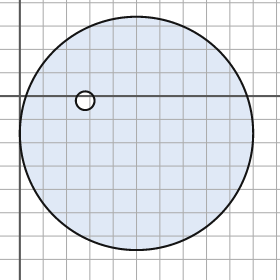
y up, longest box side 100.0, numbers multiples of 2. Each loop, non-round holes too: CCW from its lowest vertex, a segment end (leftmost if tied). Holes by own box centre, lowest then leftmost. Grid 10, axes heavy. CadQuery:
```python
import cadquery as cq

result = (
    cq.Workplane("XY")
    .moveTo(50.0, -16.0)
    .circle(50.0)
    .moveTo(28.0, -2.0)
    .circle(4.0)
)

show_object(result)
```